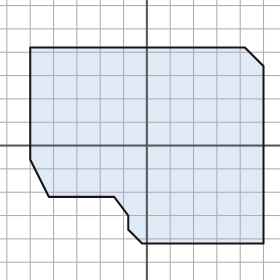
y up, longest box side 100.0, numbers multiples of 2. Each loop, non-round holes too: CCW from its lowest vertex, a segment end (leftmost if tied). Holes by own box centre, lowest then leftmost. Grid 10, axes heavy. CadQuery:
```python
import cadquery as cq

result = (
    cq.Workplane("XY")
    .moveTo(-2.0, -42.0)
    .lineTo(50.0, -42.0)
    .lineTo(50.0, 34.0)
    .lineTo(42.0, 42.0)
    .lineTo(-50.0, 42.0)
    .lineTo(-50.0, -6.0)
    .lineTo(-42.0, -22.0)
    .lineTo(-14.0, -22.0)
    .lineTo(-8.0, -30.0)
    .lineTo(-8.0, -36.0)
    .close()
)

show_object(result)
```